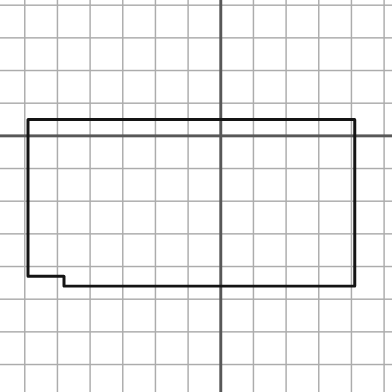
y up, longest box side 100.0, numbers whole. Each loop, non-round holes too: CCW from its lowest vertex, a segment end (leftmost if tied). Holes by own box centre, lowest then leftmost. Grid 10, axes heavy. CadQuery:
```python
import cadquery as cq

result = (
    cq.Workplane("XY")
    .moveTo(-48.0, -46.0)
    .lineTo(41.0, -46.0)
    .lineTo(41.0, 5.0)
    .lineTo(-59.0, 5.0)
    .lineTo(-59.0, -43.0)
    .lineTo(-48.0, -43.0)
    .close()
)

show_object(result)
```